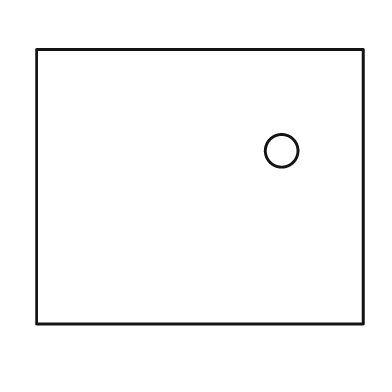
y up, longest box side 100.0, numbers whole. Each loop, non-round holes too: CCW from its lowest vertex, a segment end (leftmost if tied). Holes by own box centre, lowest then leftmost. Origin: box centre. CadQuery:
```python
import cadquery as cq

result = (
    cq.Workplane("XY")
    .moveTo(-50.0, -42.0)
    .lineTo(50.0, -42.0)
    .lineTo(50.0, 42.0)
    .lineTo(-50.0, 42.0)
    .close()
    .moveTo(25.0, 11.0)
    .circle(5.0)
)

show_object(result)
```